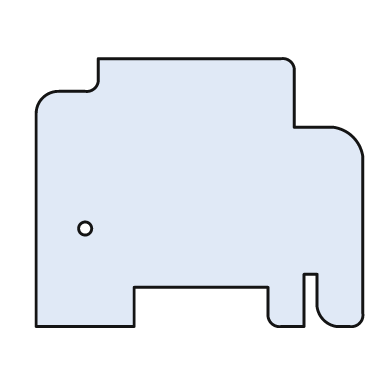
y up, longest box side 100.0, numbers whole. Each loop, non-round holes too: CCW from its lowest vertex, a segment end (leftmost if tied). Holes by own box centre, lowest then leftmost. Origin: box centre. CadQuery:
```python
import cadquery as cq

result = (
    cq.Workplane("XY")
    .moveTo(-50.0, -41.0)
    .lineTo(-20.0, -41.0)
    .lineTo(-20.0, -29.0)
    .lineTo(21.0, -29.0)
    .lineTo(21.0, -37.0)
    .threePointArc((22.0, -40.0), (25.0, -41.0))
    .lineTo(32.0, -41.0)
    .lineTo(32.0, -25.0)
    .lineTo(36.0, -25.0)
    .lineTo(36.0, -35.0)
    .threePointArc((38.0, -39.0), (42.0, -41.0))
    .lineTo(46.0, -41.0)
    .threePointArc((49.0, -40.0), (50.0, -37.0))
    .lineTo(50.0, 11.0)
    .threePointArc((47.0, 17.0), (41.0, 20.0))
    .lineTo(29.0, 20.0)
    .lineTo(29.0, 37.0)
    .threePointArc((28.0, 40.0), (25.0, 41.0))
    .lineTo(-31.0, 41.0)
    .lineTo(-31.0, 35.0)
    .threePointArc((-32.0, 32.0), (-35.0, 31.0))
    .lineTo(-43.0, 31.0)
    .threePointArc((-48.0, 29.0), (-50.0, 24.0))
    .close()
    .moveTo(-35.0, -11.0)
    .circle(2.0)
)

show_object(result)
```